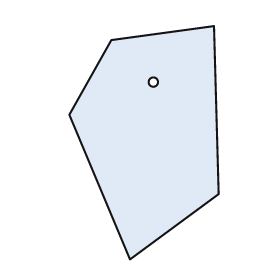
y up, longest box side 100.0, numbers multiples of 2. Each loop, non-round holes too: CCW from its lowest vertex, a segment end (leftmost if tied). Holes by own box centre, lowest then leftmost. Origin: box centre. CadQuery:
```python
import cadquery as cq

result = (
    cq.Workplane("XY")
    .moveTo(-6.0, -50.0)
    .lineTo(32.0, -22.0)
    .lineTo(30.0, 50.0)
    .lineTo(-14.0, 44.0)
    .lineTo(-32.0, 12.0)
    .close()
    .moveTo(4.0, 26.0)
    .circle(2.0)
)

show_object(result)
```